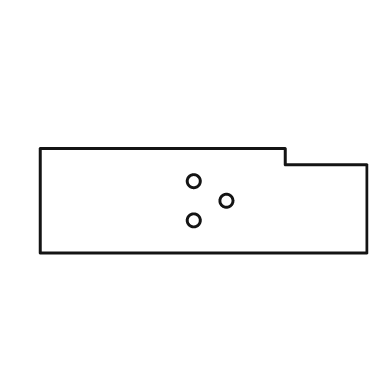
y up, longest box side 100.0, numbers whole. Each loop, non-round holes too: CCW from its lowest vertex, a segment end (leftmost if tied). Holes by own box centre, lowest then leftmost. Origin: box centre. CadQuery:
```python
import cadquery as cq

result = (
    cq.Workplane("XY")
    .moveTo(-50.0, -16.0)
    .lineTo(50.0, -16.0)
    .lineTo(50.0, 11.0)
    .lineTo(25.0, 11.0)
    .lineTo(25.0, 16.0)
    .lineTo(-50.0, 16.0)
    .close()
    .moveTo(-3.0, -6.0)
    .circle(2.0)
    .moveTo(7.0, 0.0)
    .circle(2.0)
    .moveTo(-3.0, 6.0)
    .circle(2.0)
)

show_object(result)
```